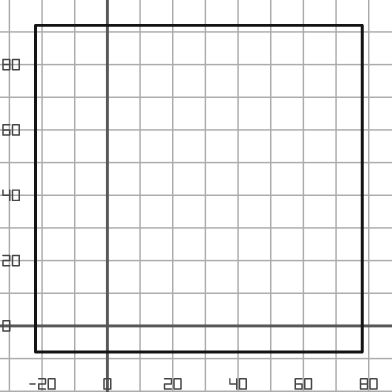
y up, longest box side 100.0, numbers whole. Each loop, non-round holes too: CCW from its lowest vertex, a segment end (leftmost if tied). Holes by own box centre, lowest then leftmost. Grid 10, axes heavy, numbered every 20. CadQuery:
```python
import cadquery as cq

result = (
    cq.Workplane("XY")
    .moveTo(-22.0, -8.0)
    .lineTo(78.0, -8.0)
    .lineTo(78.0, 92.0)
    .lineTo(-22.0, 92.0)
    .close()
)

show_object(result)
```